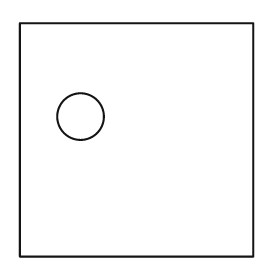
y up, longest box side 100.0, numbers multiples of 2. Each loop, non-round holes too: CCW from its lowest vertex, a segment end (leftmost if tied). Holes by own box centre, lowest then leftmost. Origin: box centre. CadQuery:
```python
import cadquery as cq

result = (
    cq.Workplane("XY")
    .moveTo(-50.0, -50.0)
    .lineTo(50.0, -50.0)
    .lineTo(50.0, 50.0)
    .lineTo(-50.0, 50.0)
    .close()
    .moveTo(-24.0, 10.0)
    .circle(10.0)
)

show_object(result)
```